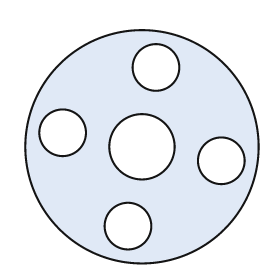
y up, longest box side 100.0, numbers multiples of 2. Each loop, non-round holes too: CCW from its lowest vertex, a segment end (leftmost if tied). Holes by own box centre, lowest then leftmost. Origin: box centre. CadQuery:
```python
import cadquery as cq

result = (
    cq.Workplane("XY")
    .moveTo(0.0, 0.0)
    .circle(50.0)
    .moveTo(-6.0, -34.0)
    .circle(10.0)
    .moveTo(34.0, -6.0)
    .circle(10.0)
    .moveTo(0.0, 0.0)
    .circle(14.0)
    .moveTo(-34.0, 6.0)
    .circle(10.0)
    .moveTo(6.0, 34.0)
    .circle(10.0)
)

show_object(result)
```